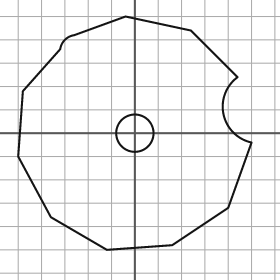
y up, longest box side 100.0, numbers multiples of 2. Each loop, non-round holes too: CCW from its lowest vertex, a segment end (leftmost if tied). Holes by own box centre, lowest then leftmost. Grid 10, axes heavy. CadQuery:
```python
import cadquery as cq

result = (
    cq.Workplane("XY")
    .moveTo(-12.0, -50.0)
    .lineTo(16.0, -48.0)
    .lineTo(40.0, -32.0)
    .lineTo(50.0, -4.0)
    .threePointArc((38.0, 8.0), (44.0, 24.0))
    .lineTo(24.0, 44.0)
    .lineTo(-4.0, 50.0)
    .lineTo(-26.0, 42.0)
    .threePointArc((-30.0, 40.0), (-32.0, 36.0))
    .lineTo(-48.0, 18.0)
    .lineTo(-50.0, -10.0)
    .lineTo(-36.0, -36.0)
    .close()
    .moveTo(0.0, 0.0)
    .circle(8.0)
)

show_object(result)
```